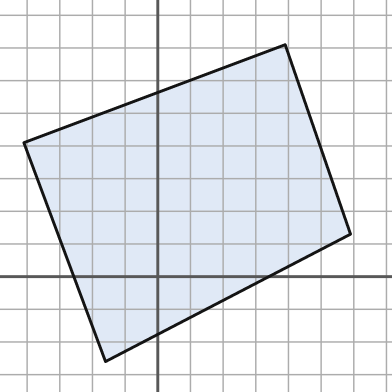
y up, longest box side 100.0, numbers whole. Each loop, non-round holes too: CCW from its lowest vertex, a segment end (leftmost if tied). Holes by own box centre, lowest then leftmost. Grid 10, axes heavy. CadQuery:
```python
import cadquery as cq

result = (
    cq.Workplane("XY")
    .moveTo(-16.0, -26.0)
    .lineTo(59.0, 13.0)
    .lineTo(39.0, 71.0)
    .lineTo(-41.0, 41.0)
    .close()
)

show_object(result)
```